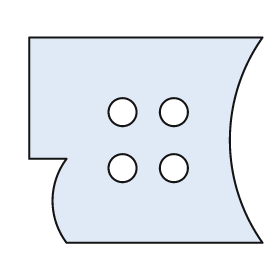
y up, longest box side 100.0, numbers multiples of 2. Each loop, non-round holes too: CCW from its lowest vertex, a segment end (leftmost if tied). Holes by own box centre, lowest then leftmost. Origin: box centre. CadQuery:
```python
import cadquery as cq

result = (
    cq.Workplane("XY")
    .moveTo(-34.0, -44.0)
    .lineTo(50.0, -44.0)
    .threePointArc((36.0, 0.0), (50.0, 44.0))
    .lineTo(-50.0, 44.0)
    .lineTo(-50.0, -8.0)
    .lineTo(-34.0, -8.0)
    .threePointArc((-40.0, -26.0), (-34.0, -44.0))
    .close()
    .moveTo(-10.0, -12.0)
    .circle(6.0)
    .moveTo(12.0, -12.0)
    .circle(6.0)
    .moveTo(-10.0, 12.0)
    .circle(6.0)
    .moveTo(12.0, 12.0)
    .circle(6.0)
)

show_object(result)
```